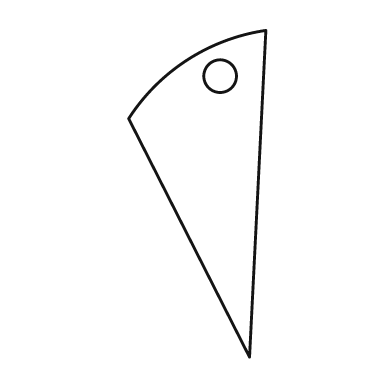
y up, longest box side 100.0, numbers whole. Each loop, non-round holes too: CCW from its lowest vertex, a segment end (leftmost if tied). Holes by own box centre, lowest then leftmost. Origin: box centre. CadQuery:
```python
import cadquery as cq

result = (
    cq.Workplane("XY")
    .moveTo(16.0, -50.0)
    .lineTo(21.0, 50.0)
    .threePointArc((-3.0, 41.0), (-21.0, 23.0))
    .close()
    .moveTo(7.0, 36.0)
    .circle(5.0)
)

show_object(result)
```